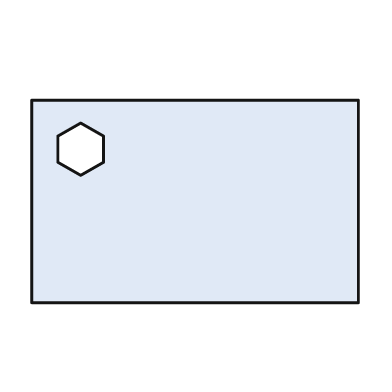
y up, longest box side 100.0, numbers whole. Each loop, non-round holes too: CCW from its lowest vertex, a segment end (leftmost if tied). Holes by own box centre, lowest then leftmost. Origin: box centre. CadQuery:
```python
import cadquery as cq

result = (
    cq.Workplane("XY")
    .moveTo(-50.0, -31.0)
    .lineTo(50.0, -31.0)
    .lineTo(50.0, 31.0)
    .lineTo(-50.0, 31.0)
    .close()
    .moveTo(-35.0, 8.0)
    .lineTo(-28.0, 12.0)
    .lineTo(-28.0, 20.0)
    .lineTo(-35.0, 24.0)
    .lineTo(-42.0, 20.0)
    .lineTo(-42.0, 12.0)
    .close()
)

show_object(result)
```